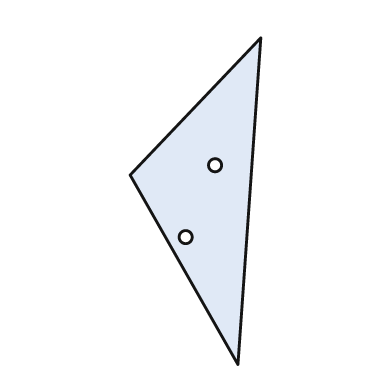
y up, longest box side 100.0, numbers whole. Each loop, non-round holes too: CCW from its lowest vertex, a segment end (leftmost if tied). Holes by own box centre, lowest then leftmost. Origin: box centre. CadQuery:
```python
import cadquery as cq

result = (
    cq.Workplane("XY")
    .moveTo(13.0, -50.0)
    .lineTo(20.0, 50.0)
    .lineTo(-20.0, 8.0)
    .close()
    .moveTo(-3.0, -11.0)
    .circle(2.0)
    .moveTo(6.0, 11.0)
    .circle(2.0)
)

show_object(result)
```